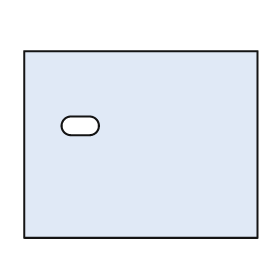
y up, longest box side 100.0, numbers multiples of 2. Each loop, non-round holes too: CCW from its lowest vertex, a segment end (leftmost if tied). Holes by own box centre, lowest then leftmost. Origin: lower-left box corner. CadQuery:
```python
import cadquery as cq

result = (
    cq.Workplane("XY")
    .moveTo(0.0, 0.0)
    .lineTo(100.0, 0.0)
    .lineTo(100.0, 80.0)
    .lineTo(0.0, 80.0)
    .close()
    .moveTo(20.0, 44.0)
    .lineTo(28.0, 44.0)
    .threePointArc((32.0, 48.0), (28.0, 52.0))
    .lineTo(20.0, 52.0)
    .threePointArc((16.0, 48.0), (20.0, 44.0))
    .close()
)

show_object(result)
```